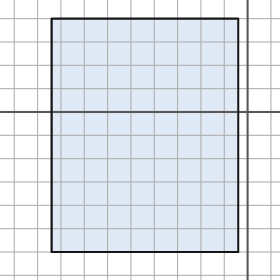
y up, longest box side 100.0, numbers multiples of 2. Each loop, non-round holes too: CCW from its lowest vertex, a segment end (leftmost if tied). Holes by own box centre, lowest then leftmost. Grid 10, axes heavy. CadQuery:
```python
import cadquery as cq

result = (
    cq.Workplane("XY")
    .moveTo(-84.0, -60.0)
    .lineTo(-4.0, -60.0)
    .lineTo(-4.0, 40.0)
    .lineTo(-84.0, 40.0)
    .close()
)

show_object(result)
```